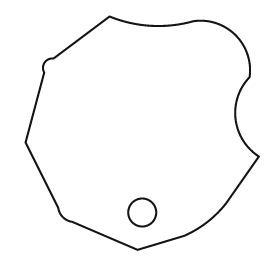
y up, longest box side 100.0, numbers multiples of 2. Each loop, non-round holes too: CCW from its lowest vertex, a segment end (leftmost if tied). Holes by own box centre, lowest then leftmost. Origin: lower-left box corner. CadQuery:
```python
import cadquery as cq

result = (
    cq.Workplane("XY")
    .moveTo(48.0, 0.0)
    .lineTo(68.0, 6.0)
    .threePointArc((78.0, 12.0), (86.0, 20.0))
    .lineTo(100.0, 40.0)
    .threePointArc((90.0, 56.0), (96.0, 74.0))
    .threePointArc((90.0, 92.0), (72.0, 98.0))
    .threePointArc((54.0, 96.0), (36.0, 100.0))
    .lineTo(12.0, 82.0)
    .threePointArc((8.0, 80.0), (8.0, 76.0))
    .lineTo(0.0, 46.0)
    .lineTo(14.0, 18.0)
    .threePointArc((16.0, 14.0), (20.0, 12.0))
    .close()
    .moveTo(50.0, 16.0)
    .circle(6.0)
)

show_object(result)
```